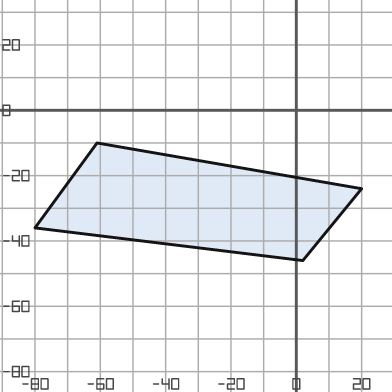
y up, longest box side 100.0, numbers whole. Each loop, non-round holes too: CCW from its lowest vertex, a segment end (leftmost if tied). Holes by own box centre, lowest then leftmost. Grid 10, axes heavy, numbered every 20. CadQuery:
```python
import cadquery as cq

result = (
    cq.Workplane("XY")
    .moveTo(2.0, -46.0)
    .lineTo(20.0, -24.0)
    .lineTo(-61.0, -10.0)
    .lineTo(-80.0, -36.0)
    .close()
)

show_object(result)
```